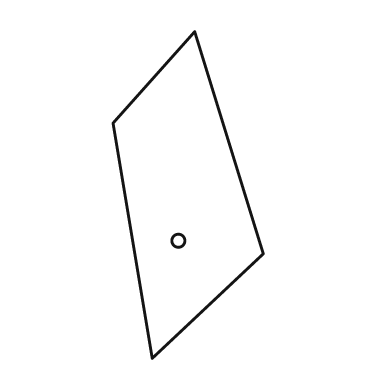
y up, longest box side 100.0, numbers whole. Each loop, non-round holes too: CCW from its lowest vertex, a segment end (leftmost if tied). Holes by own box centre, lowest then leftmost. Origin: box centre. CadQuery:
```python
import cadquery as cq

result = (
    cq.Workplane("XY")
    .moveTo(-11.0, -50.0)
    .lineTo(23.0, -18.0)
    .lineTo(2.0, 50.0)
    .lineTo(-23.0, 22.0)
    .close()
    .moveTo(-3.0, -14.0)
    .circle(2.0)
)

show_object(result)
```